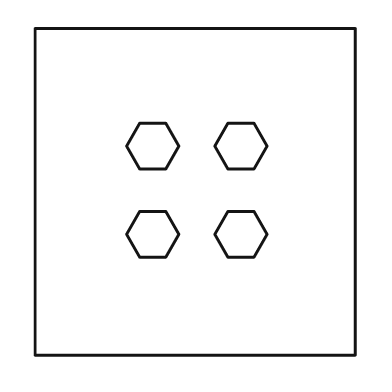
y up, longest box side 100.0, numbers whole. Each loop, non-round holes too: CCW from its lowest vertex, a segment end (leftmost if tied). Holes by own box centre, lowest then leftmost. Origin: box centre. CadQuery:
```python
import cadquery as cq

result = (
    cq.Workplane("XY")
    .moveTo(-49.0, -50.0)
    .lineTo(49.0, -50.0)
    .lineTo(49.0, 50.0)
    .lineTo(-49.0, 50.0)
    .close()
    .moveTo(-17.0, -20.0)
    .lineTo(-9.0, -20.0)
    .lineTo(-5.0, -13.0)
    .lineTo(-9.0, -6.0)
    .lineTo(-17.0, -6.0)
    .lineTo(-21.0, -13.0)
    .close()
    .moveTo(10.0, -20.0)
    .lineTo(18.0, -20.0)
    .lineTo(22.0, -13.0)
    .lineTo(18.0, -6.0)
    .lineTo(10.0, -6.0)
    .lineTo(6.0, -13.0)
    .close()
    .moveTo(-17.0, 7.0)
    .lineTo(-9.0, 7.0)
    .lineTo(-5.0, 14.0)
    .lineTo(-9.0, 21.0)
    .lineTo(-17.0, 21.0)
    .lineTo(-21.0, 14.0)
    .close()
    .moveTo(10.0, 7.0)
    .lineTo(18.0, 7.0)
    .lineTo(22.0, 14.0)
    .lineTo(18.0, 21.0)
    .lineTo(10.0, 21.0)
    .lineTo(6.0, 14.0)
    .close()
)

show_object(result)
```